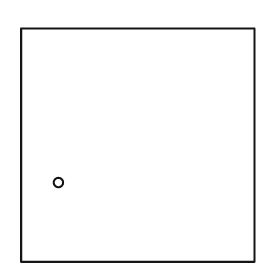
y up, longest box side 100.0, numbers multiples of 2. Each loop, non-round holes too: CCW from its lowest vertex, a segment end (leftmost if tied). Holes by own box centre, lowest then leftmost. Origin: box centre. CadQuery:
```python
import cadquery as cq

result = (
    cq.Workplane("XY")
    .moveTo(-50.0, -50.0)
    .lineTo(50.0, -50.0)
    .lineTo(50.0, 50.0)
    .lineTo(-50.0, 50.0)
    .close()
    .moveTo(-34.0, -16.0)
    .circle(2.0)
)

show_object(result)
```